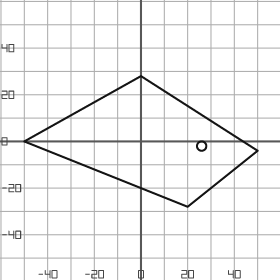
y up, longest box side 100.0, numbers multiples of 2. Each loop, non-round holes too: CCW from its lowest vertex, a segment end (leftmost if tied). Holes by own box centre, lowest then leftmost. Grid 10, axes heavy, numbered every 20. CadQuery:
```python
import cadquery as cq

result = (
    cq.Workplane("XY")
    .moveTo(20.0, -28.0)
    .lineTo(50.0, -4.0)
    .lineTo(0.0, 28.0)
    .lineTo(-50.0, 0.0)
    .close()
    .moveTo(26.0, -2.0)
    .circle(2.0)
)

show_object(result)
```